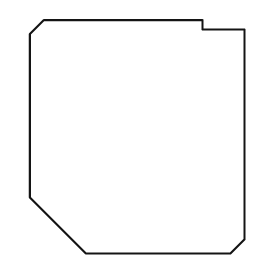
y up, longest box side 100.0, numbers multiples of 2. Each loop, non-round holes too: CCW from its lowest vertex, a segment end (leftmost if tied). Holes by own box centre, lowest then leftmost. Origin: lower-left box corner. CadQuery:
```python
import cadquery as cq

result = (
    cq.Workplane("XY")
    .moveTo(24.0, 0.0)
    .lineTo(86.0, 0.0)
    .lineTo(92.0, 6.0)
    .lineTo(92.0, 96.0)
    .lineTo(74.0, 96.0)
    .lineTo(74.0, 100.0)
    .lineTo(6.0, 100.0)
    .lineTo(0.0, 94.0)
    .lineTo(0.0, 24.0)
    .close()
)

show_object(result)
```